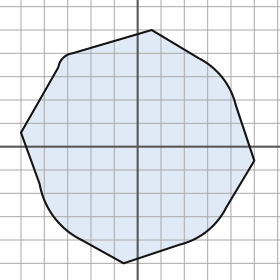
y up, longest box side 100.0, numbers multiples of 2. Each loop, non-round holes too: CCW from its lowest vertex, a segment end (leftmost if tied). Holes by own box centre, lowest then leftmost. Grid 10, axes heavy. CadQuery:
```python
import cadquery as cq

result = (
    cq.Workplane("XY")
    .moveTo(-6.0, -50.0)
    .lineTo(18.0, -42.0)
    .threePointArc((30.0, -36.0), (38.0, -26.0))
    .lineTo(50.0, -6.0)
    .lineTo(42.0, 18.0)
    .threePointArc((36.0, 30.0), (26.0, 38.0))
    .lineTo(6.0, 50.0)
    .lineTo(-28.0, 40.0)
    .threePointArc((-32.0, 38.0), (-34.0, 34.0))
    .lineTo(-50.0, 6.0)
    .lineTo(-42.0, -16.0)
    .threePointArc((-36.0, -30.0), (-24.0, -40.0))
    .close()
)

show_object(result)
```